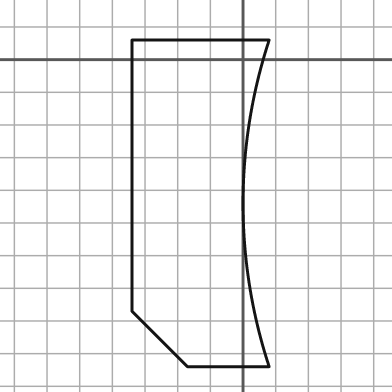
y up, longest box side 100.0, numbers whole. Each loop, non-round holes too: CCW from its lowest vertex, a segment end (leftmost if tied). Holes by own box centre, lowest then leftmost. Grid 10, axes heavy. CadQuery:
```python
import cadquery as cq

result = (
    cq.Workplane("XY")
    .moveTo(-17.0, -94.0)
    .lineTo(8.0, -94.0)
    .threePointArc((0.0, -44.0), (8.0, 6.0))
    .lineTo(-34.0, 6.0)
    .lineTo(-34.0, -77.0)
    .close()
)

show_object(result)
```